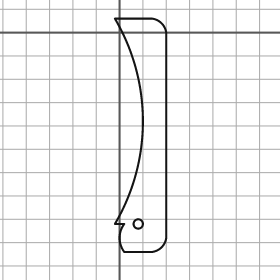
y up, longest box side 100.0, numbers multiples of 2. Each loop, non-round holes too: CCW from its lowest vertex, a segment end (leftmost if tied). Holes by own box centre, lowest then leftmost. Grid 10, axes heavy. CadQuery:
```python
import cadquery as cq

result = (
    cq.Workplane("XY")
    .moveTo(2.0, -94.0)
    .lineTo(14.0, -94.0)
    .threePointArc((18.0, -92.0), (20.0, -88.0))
    .lineTo(20.0, 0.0)
    .threePointArc((18.0, 4.0), (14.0, 6.0))
    .lineTo(-2.0, 6.0)
    .threePointArc((10.0, -38.0), (-2.0, -82.0))
    .lineTo(2.0, -82.0)
    .threePointArc((0.0, -88.0), (2.0, -94.0))
    .close()
    .moveTo(8.0, -82.0)
    .circle(2.0)
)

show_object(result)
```